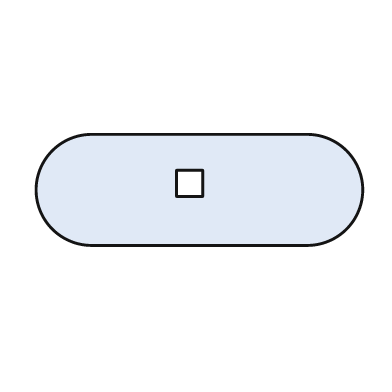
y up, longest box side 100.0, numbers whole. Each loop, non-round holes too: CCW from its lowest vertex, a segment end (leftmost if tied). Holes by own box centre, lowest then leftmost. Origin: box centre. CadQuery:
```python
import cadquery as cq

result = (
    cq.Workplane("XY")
    .moveTo(-33.0, -17.0)
    .lineTo(33.0, -17.0)
    .threePointArc((50.0, 0.0), (33.0, 17.0))
    .lineTo(-33.0, 17.0)
    .threePointArc((-50.0, 0.0), (-33.0, -17.0))
    .close()
    .moveTo(-7.0, -2.0)
    .lineTo(1.0, -2.0)
    .lineTo(1.0, 6.0)
    .lineTo(-7.0, 6.0)
    .close()
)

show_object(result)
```